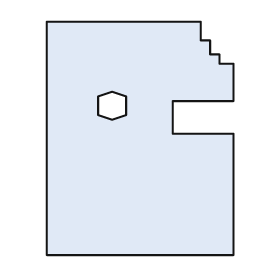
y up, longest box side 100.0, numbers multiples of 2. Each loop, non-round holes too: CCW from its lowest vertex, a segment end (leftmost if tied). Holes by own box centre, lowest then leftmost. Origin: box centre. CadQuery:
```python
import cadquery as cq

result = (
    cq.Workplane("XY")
    .moveTo(-40.0, -50.0)
    .lineTo(40.0, -50.0)
    .lineTo(40.0, 2.0)
    .lineTo(14.0, 2.0)
    .lineTo(14.0, 16.0)
    .lineTo(40.0, 16.0)
    .lineTo(40.0, 32.0)
    .lineTo(34.0, 32.0)
    .lineTo(34.0, 36.0)
    .lineTo(30.0, 36.0)
    .lineTo(30.0, 42.0)
    .lineTo(26.0, 42.0)
    .lineTo(26.0, 50.0)
    .lineTo(-40.0, 50.0)
    .close()
    .moveTo(-12.0, 8.0)
    .lineTo(-6.0, 10.0)
    .lineTo(-6.0, 18.0)
    .lineTo(-12.0, 20.0)
    .lineTo(-18.0, 18.0)
    .lineTo(-18.0, 10.0)
    .close()
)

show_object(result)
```